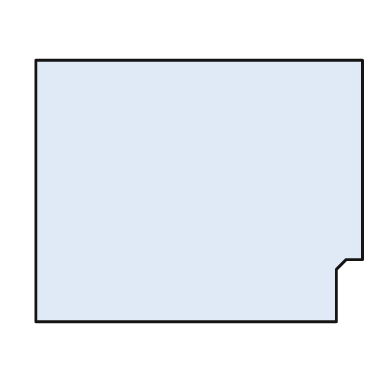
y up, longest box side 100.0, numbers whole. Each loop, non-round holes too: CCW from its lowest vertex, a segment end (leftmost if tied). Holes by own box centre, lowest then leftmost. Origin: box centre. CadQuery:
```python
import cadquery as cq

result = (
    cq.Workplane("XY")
    .moveTo(-50.0, -40.0)
    .lineTo(42.0, -40.0)
    .lineTo(42.0, -24.0)
    .lineTo(45.0, -21.0)
    .lineTo(50.0, -21.0)
    .lineTo(50.0, 40.0)
    .lineTo(-50.0, 40.0)
    .close()
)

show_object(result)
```